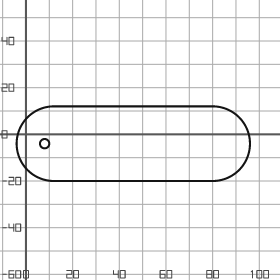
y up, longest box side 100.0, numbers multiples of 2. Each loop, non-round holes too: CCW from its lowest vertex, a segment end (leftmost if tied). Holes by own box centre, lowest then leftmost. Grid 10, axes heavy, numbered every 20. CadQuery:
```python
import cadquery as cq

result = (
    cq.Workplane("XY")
    .moveTo(12.0, -20.0)
    .lineTo(80.0, -20.0)
    .threePointArc((96.0, -4.0), (80.0, 12.0))
    .lineTo(12.0, 12.0)
    .threePointArc((-4.0, -4.0), (12.0, -20.0))
    .close()
    .moveTo(8.0, -4.0)
    .circle(2.0)
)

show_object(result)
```